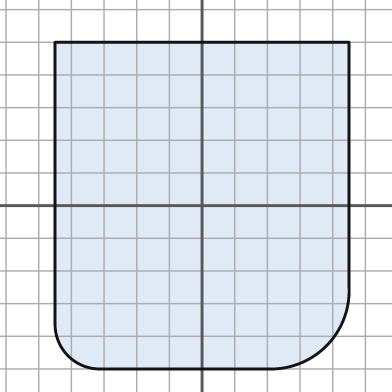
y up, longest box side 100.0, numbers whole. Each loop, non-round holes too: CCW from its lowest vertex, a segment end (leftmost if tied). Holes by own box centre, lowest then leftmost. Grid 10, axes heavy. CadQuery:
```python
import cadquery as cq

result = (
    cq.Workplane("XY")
    .moveTo(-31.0, -50.0)
    .lineTo(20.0, -50.0)
    .threePointArc((38.0, -43.0), (45.0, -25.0))
    .lineTo(45.0, 50.0)
    .lineTo(-45.0, 50.0)
    .lineTo(-45.0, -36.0)
    .threePointArc((-41.0, -46.0), (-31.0, -50.0))
    .close()
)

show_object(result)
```